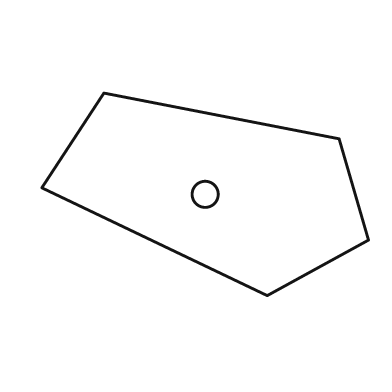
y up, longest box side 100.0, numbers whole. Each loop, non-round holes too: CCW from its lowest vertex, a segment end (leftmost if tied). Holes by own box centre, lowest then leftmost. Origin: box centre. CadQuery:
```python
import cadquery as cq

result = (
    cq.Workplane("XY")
    .moveTo(19.0, -31.0)
    .lineTo(50.0, -14.0)
    .lineTo(41.0, 17.0)
    .lineTo(-31.0, 31.0)
    .lineTo(-50.0, 2.0)
    .close()
    .moveTo(0.0, 0.0)
    .circle(4.0)
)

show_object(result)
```